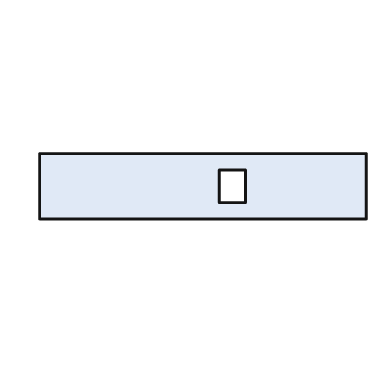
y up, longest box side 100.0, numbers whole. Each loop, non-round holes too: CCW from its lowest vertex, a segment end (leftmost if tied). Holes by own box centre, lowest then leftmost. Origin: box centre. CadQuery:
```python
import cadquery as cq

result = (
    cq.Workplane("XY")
    .moveTo(-50.0, -10.0)
    .lineTo(50.0, -10.0)
    .lineTo(50.0, 10.0)
    .lineTo(-50.0, 10.0)
    .close()
    .moveTo(5.0, -5.0)
    .lineTo(13.0, -5.0)
    .lineTo(13.0, 5.0)
    .lineTo(5.0, 5.0)
    .close()
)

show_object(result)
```